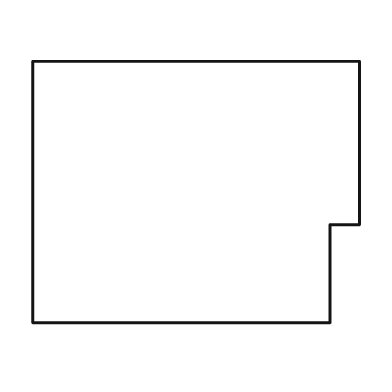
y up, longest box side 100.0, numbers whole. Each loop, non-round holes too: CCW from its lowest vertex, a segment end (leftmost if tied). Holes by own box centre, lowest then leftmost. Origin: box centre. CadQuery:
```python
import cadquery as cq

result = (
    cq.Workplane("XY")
    .moveTo(-50.0, -40.0)
    .lineTo(41.0, -40.0)
    .lineTo(41.0, -10.0)
    .lineTo(50.0, -10.0)
    .lineTo(50.0, 40.0)
    .lineTo(-50.0, 40.0)
    .close()
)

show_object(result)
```